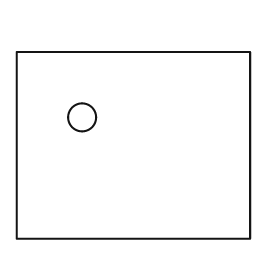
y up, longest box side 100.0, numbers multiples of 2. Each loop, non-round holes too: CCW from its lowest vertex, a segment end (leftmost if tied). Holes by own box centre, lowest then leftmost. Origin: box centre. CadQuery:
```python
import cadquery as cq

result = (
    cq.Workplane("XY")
    .moveTo(-50.0, -40.0)
    .lineTo(50.0, -40.0)
    .lineTo(50.0, 40.0)
    .lineTo(-50.0, 40.0)
    .close()
    .moveTo(-22.0, 12.0)
    .circle(6.0)
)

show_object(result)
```